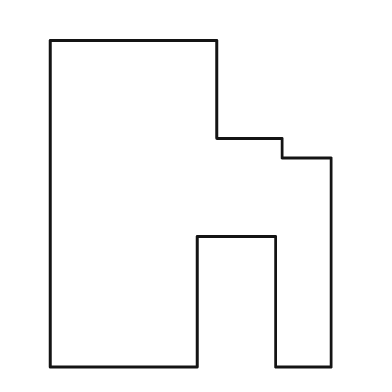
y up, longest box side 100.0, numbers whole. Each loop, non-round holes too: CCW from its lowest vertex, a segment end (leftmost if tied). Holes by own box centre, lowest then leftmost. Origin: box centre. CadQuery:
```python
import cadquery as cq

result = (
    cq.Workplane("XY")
    .moveTo(-43.0, -50.0)
    .lineTo(2.0, -50.0)
    .lineTo(2.0, -10.0)
    .lineTo(26.0, -10.0)
    .lineTo(26.0, -50.0)
    .lineTo(43.0, -50.0)
    .lineTo(43.0, 14.0)
    .lineTo(28.0, 14.0)
    .lineTo(28.0, 20.0)
    .lineTo(8.0, 20.0)
    .lineTo(8.0, 50.0)
    .lineTo(-43.0, 50.0)
    .close()
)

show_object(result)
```